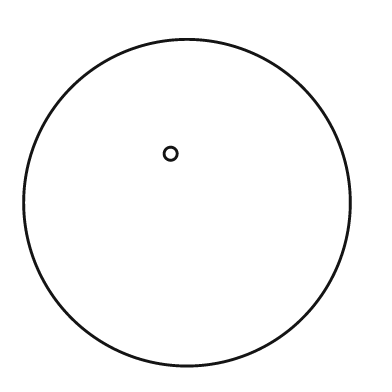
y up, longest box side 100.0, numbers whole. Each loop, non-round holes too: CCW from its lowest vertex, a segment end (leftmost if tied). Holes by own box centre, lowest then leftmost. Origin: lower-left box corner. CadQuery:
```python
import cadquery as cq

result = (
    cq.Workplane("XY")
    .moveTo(50.0, 50.0)
    .circle(50.0)
    .moveTo(45.0, 65.0)
    .circle(2.0)
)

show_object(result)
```